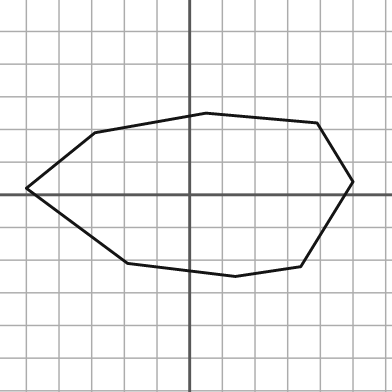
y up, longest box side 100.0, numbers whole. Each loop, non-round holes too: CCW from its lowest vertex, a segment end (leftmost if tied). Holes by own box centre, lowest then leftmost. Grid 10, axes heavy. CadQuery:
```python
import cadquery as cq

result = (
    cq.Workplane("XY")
    .moveTo(14.0, -25.0)
    .lineTo(34.0, -22.0)
    .lineTo(50.0, 4.0)
    .lineTo(39.0, 22.0)
    .lineTo(5.0, 25.0)
    .lineTo(-29.0, 19.0)
    .lineTo(-50.0, 2.0)
    .lineTo(-19.0, -21.0)
    .close()
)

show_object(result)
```